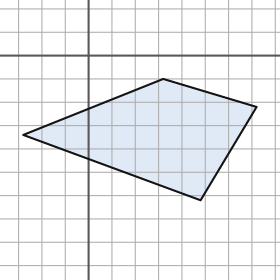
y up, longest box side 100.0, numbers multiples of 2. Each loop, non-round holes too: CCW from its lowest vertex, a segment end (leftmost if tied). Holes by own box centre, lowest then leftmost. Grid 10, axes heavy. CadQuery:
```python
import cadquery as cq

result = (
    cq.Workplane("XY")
    .moveTo(48.0, -62.0)
    .lineTo(72.0, -22.0)
    .lineTo(32.0, -10.0)
    .lineTo(-28.0, -34.0)
    .close()
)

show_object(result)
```